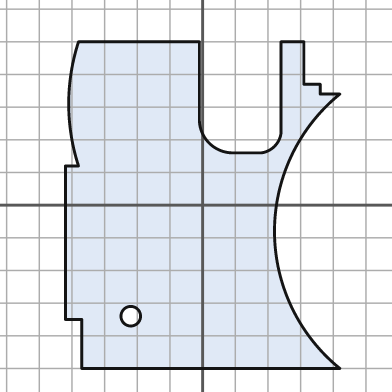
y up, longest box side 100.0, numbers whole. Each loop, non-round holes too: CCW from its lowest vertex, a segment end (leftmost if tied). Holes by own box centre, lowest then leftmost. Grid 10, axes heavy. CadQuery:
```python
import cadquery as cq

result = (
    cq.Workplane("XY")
    .moveTo(-37.0, -50.0)
    .lineTo(42.0, -50.0)
    .threePointArc((22.0, -8.0), (42.0, 34.0))
    .lineTo(36.0, 34.0)
    .lineTo(36.0, 37.0)
    .lineTo(31.0, 37.0)
    .lineTo(31.0, 50.0)
    .lineTo(24.0, 50.0)
    .lineTo(24.0, 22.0)
    .threePointArc((22.0, 18.0), (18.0, 16.0))
    .lineTo(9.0, 16.0)
    .threePointArc((2.0, 19.0), (-1.0, 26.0))
    .lineTo(-1.0, 50.0)
    .lineTo(-38.0, 50.0)
    .threePointArc((-41.0, 31.0), (-38.0, 12.0))
    .lineTo(-42.0, 12.0)
    .lineTo(-42.0, -35.0)
    .lineTo(-37.0, -35.0)
    .close()
    .moveTo(-22.0, -34.0)
    .circle(3.0)
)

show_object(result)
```